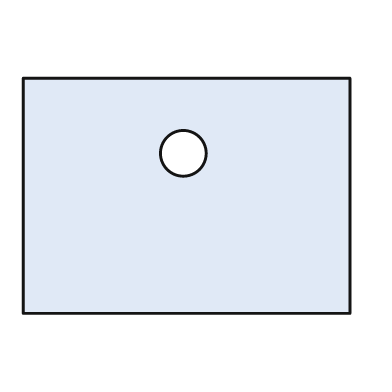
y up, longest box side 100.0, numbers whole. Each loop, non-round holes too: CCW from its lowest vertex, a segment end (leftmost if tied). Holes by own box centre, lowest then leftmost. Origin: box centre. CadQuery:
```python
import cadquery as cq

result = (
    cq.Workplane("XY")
    .moveTo(-50.0, -36.0)
    .lineTo(50.0, -36.0)
    .lineTo(50.0, 36.0)
    .lineTo(-50.0, 36.0)
    .close()
    .moveTo(-1.0, 13.0)
    .circle(7.0)
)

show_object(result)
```